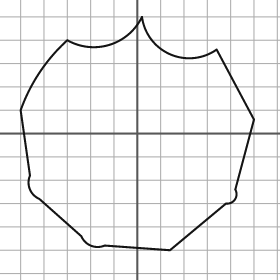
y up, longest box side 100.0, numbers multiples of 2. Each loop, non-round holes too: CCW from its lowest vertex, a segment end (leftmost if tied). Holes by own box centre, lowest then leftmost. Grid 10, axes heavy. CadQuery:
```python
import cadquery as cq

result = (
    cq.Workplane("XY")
    .moveTo(14.0, -50.0)
    .lineTo(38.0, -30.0)
    .threePointArc((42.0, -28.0), (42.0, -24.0))
    .lineTo(50.0, 6.0)
    .lineTo(34.0, 36.0)
    .threePointArc((14.0, 34.0), (2.0, 50.0))
    .threePointArc((-12.0, 38.0), (-30.0, 40.0))
    .threePointArc((-42.0, 26.0), (-50.0, 10.0))
    .lineTo(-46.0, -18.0)
    .threePointArc((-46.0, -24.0), (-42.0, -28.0))
    .lineTo(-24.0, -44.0)
    .threePointArc((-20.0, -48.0), (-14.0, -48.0))
    .close()
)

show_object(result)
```